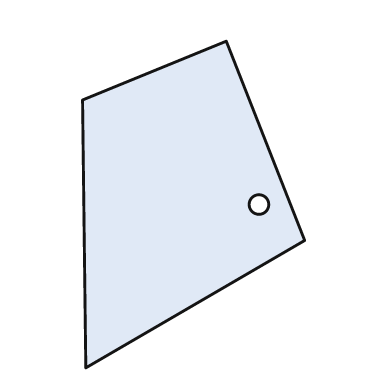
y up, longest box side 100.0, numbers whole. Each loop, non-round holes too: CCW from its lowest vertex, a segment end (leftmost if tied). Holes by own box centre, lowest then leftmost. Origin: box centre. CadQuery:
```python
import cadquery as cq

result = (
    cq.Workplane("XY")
    .moveTo(-33.0, -50.0)
    .lineTo(34.0, -11.0)
    .lineTo(10.0, 50.0)
    .lineTo(-34.0, 32.0)
    .close()
    .moveTo(20.0, 0.0)
    .circle(3.0)
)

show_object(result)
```